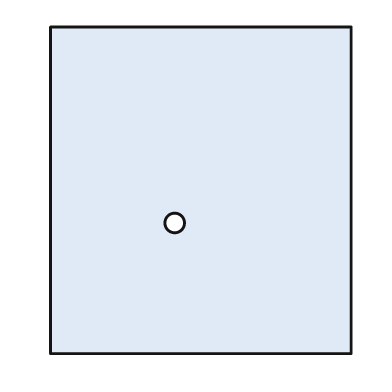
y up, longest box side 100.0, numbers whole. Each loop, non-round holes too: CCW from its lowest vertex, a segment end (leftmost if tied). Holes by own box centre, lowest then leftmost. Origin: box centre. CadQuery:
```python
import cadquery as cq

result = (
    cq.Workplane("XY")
    .moveTo(-46.0, -50.0)
    .lineTo(46.0, -50.0)
    .lineTo(46.0, 50.0)
    .lineTo(-46.0, 50.0)
    .close()
    .moveTo(-8.0, -10.0)
    .circle(3.0)
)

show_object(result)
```